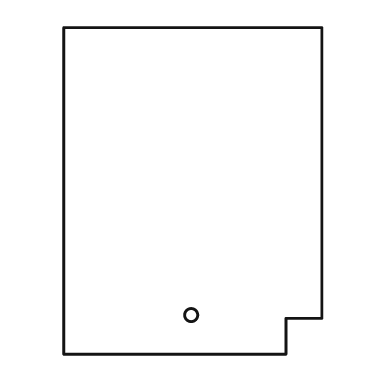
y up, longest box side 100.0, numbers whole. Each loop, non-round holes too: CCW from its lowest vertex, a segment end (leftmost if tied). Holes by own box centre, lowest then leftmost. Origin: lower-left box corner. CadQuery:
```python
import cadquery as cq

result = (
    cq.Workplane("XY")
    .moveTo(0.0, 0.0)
    .lineTo(68.0, 0.0)
    .lineTo(68.0, 11.0)
    .lineTo(79.0, 11.0)
    .lineTo(79.0, 100.0)
    .lineTo(0.0, 100.0)
    .close()
    .moveTo(39.0, 12.0)
    .circle(2.0)
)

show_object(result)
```